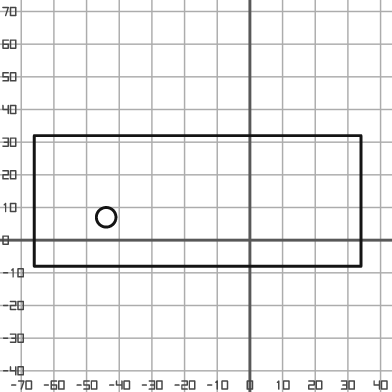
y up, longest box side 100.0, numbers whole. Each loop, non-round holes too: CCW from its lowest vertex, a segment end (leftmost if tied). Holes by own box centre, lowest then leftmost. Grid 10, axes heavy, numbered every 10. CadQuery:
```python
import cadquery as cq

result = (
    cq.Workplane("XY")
    .moveTo(-66.0, -8.0)
    .lineTo(34.0, -8.0)
    .lineTo(34.0, 32.0)
    .lineTo(-66.0, 32.0)
    .close()
    .moveTo(-44.0, 7.0)
    .circle(3.0)
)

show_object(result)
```